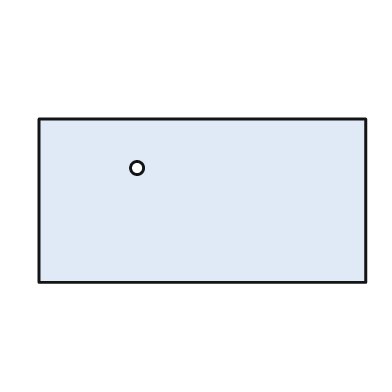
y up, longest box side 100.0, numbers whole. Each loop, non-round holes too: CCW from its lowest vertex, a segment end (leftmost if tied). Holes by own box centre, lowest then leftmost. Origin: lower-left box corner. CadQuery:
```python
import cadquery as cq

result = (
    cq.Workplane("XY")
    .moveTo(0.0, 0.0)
    .lineTo(100.0, 0.0)
    .lineTo(100.0, 50.0)
    .lineTo(0.0, 50.0)
    .close()
    .moveTo(30.0, 35.0)
    .circle(2.0)
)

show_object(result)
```